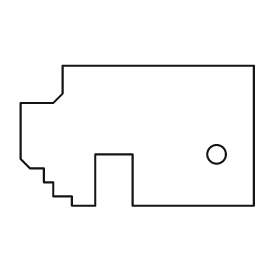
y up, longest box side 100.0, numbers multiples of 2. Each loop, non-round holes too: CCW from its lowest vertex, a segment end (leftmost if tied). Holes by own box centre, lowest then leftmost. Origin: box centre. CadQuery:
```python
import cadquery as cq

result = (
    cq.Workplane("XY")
    .moveTo(-28.0, -30.0)
    .lineTo(-18.0, -30.0)
    .lineTo(-18.0, -8.0)
    .lineTo(-2.0, -8.0)
    .lineTo(-2.0, -30.0)
    .lineTo(50.0, -30.0)
    .lineTo(50.0, 30.0)
    .lineTo(-32.0, 30.0)
    .lineTo(-32.0, 18.0)
    .lineTo(-36.0, 14.0)
    .lineTo(-50.0, 14.0)
    .lineTo(-50.0, -10.0)
    .lineTo(-46.0, -14.0)
    .lineTo(-40.0, -14.0)
    .lineTo(-40.0, -20.0)
    .lineTo(-36.0, -20.0)
    .lineTo(-36.0, -26.0)
    .lineTo(-28.0, -26.0)
    .close()
    .moveTo(34.0, -8.0)
    .circle(4.0)
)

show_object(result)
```